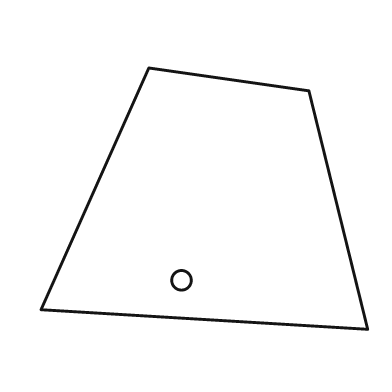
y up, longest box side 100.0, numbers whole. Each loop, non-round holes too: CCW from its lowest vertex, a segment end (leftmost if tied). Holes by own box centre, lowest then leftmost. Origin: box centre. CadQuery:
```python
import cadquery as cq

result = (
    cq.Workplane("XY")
    .moveTo(50.0, -40.0)
    .lineTo(32.0, 33.0)
    .lineTo(-17.0, 40.0)
    .lineTo(-50.0, -34.0)
    .close()
    .moveTo(-7.0, -25.0)
    .circle(3.0)
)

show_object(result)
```